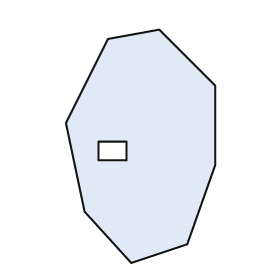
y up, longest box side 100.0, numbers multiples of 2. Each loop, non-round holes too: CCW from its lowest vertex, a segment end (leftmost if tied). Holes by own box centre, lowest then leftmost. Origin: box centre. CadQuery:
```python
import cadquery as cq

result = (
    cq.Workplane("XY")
    .moveTo(-4.0, -50.0)
    .lineTo(20.0, -42.0)
    .lineTo(32.0, -8.0)
    .lineTo(32.0, 26.0)
    .lineTo(8.0, 50.0)
    .lineTo(-14.0, 46.0)
    .lineTo(-32.0, 10.0)
    .lineTo(-24.0, -28.0)
    .close()
    .moveTo(-18.0, -6.0)
    .lineTo(-6.0, -6.0)
    .lineTo(-6.0, 2.0)
    .lineTo(-18.0, 2.0)
    .close()
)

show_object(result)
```